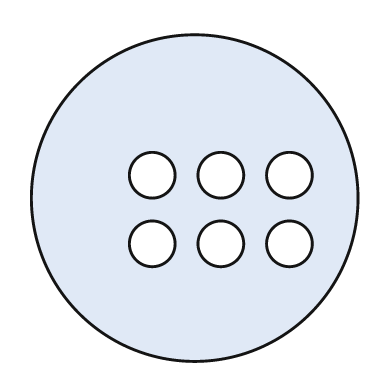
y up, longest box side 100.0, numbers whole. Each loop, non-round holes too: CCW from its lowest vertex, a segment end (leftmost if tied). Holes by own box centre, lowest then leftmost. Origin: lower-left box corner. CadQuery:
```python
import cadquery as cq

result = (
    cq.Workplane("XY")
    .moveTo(50.0, 50.0)
    .circle(50.0)
    .moveTo(37.0, 36.0)
    .circle(7.0)
    .moveTo(58.0, 36.0)
    .circle(7.0)
    .moveTo(79.0, 36.0)
    .circle(7.0)
    .moveTo(37.0, 57.0)
    .circle(7.0)
    .moveTo(58.0, 57.0)
    .circle(7.0)
    .moveTo(79.0, 57.0)
    .circle(7.0)
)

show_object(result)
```